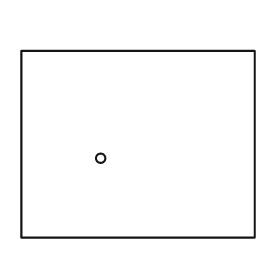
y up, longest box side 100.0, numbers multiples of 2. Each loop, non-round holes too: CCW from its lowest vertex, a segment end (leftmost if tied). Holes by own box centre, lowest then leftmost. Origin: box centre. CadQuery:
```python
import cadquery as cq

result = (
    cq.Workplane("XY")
    .moveTo(-50.0, -40.0)
    .lineTo(50.0, -40.0)
    .lineTo(50.0, 40.0)
    .lineTo(-50.0, 40.0)
    .close()
    .moveTo(-16.0, -6.0)
    .circle(2.0)
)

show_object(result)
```